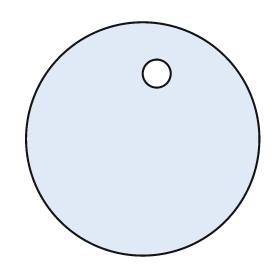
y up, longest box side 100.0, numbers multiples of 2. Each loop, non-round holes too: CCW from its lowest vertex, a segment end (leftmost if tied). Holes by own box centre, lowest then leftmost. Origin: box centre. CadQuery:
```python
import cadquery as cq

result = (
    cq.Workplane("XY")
    .moveTo(0.0, 0.0)
    .circle(50.0)
    .moveTo(6.0, 28.0)
    .circle(6.0)
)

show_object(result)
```